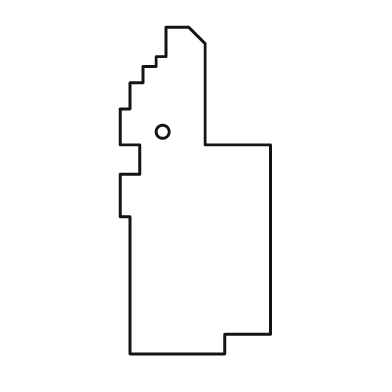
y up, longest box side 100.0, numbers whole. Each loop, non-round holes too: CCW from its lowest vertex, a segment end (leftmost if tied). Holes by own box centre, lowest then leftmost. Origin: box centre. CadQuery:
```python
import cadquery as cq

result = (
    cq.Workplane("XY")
    .moveTo(-20.0, -50.0)
    .lineTo(9.0, -50.0)
    .lineTo(9.0, -44.0)
    .lineTo(23.0, -44.0)
    .lineTo(23.0, 14.0)
    .lineTo(3.0, 14.0)
    .lineTo(3.0, 45.0)
    .lineTo(-2.0, 50.0)
    .lineTo(-9.0, 50.0)
    .lineTo(-9.0, 41.0)
    .lineTo(-12.0, 41.0)
    .lineTo(-12.0, 38.0)
    .lineTo(-16.0, 38.0)
    .lineTo(-16.0, 33.0)
    .lineTo(-20.0, 33.0)
    .lineTo(-20.0, 25.0)
    .lineTo(-23.0, 25.0)
    .lineTo(-23.0, 14.0)
    .lineTo(-17.0, 14.0)
    .lineTo(-17.0, 5.0)
    .lineTo(-23.0, 5.0)
    .lineTo(-23.0, -8.0)
    .lineTo(-20.0, -8.0)
    .close()
    .moveTo(-10.0, 18.0)
    .circle(2.0)
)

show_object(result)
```